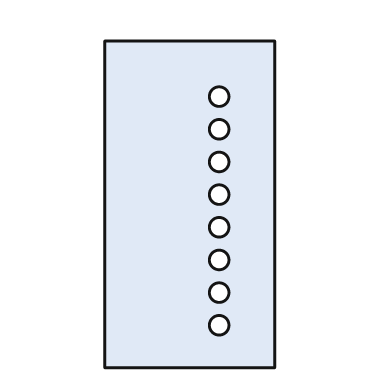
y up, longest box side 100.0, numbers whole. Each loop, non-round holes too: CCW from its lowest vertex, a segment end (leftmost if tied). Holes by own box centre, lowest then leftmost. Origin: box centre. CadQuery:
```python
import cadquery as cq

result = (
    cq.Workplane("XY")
    .moveTo(-26.0, -50.0)
    .lineTo(26.0, -50.0)
    .lineTo(26.0, 50.0)
    .lineTo(-26.0, 50.0)
    .close()
    .moveTo(9.0, -37.0)
    .circle(3.0)
    .moveTo(9.0, -27.0)
    .circle(3.0)
    .moveTo(9.0, -17.0)
    .circle(3.0)
    .moveTo(9.0, -7.0)
    .circle(3.0)
    .moveTo(9.0, 3.0)
    .circle(3.0)
    .moveTo(9.0, 13.0)
    .circle(3.0)
    .moveTo(9.0, 23.0)
    .circle(3.0)
    .moveTo(9.0, 33.0)
    .circle(3.0)
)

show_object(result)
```